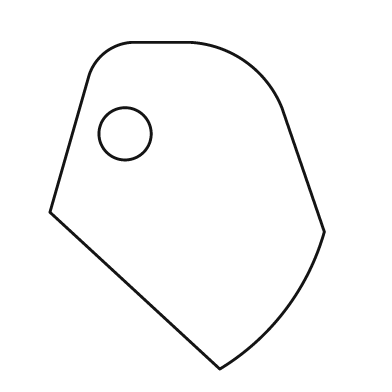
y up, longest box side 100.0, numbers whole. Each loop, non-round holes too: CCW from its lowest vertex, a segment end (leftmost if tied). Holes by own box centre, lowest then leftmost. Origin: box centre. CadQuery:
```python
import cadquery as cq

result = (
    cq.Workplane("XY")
    .moveTo(10.0, -50.0)
    .threePointArc((30.0, -32.0), (42.0, -8.0))
    .lineTo(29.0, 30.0)
    .threePointArc((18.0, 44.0), (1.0, 50.0))
    .lineTo(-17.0, 50.0)
    .threePointArc((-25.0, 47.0), (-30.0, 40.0))
    .lineTo(-42.0, -2.0)
    .close()
    .moveTo(-19.0, 22.0)
    .circle(8.0)
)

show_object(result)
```